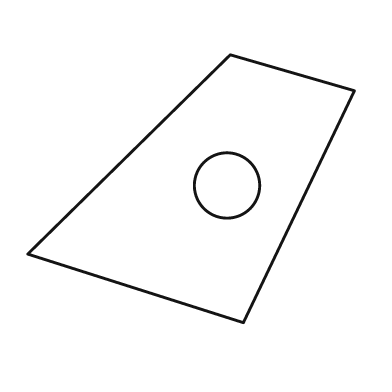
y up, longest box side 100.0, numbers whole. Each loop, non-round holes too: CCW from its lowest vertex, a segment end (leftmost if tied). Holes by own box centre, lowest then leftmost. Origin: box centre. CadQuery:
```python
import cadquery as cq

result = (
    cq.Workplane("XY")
    .moveTo(16.0, -41.0)
    .lineTo(50.0, 30.0)
    .lineTo(12.0, 41.0)
    .lineTo(-50.0, -20.0)
    .close()
    .moveTo(11.0, 1.0)
    .circle(10.0)
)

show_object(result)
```